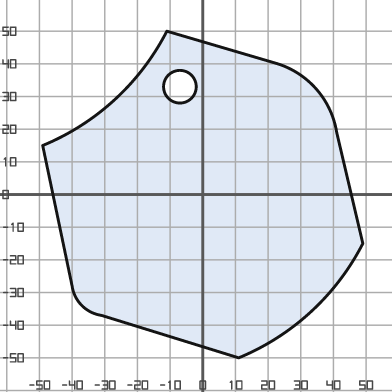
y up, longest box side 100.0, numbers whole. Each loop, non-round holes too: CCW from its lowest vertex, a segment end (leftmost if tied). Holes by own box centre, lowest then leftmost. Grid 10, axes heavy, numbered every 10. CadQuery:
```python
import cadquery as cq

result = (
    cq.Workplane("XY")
    .moveTo(11.0, -50.0)
    .threePointArc((33.0, -36.0), (49.0, -15.0))
    .lineTo(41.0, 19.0)
    .threePointArc((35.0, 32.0), (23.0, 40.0))
    .lineTo(-11.0, 50.0)
    .threePointArc((-27.0, 29.0), (-49.0, 15.0))
    .lineTo(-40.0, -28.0)
    .threePointArc((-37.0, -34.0), (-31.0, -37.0))
    .close()
    .moveTo(-7.0, 33.0)
    .circle(5.0)
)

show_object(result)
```